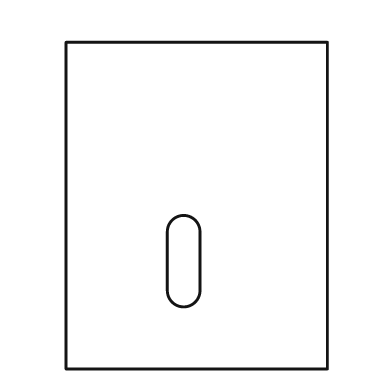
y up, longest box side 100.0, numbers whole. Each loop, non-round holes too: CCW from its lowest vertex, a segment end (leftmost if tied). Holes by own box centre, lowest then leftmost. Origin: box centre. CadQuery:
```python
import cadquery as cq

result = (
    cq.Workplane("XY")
    .moveTo(-40.0, -50.0)
    .lineTo(40.0, -50.0)
    .lineTo(40.0, 50.0)
    .lineTo(-40.0, 50.0)
    .close()
    .moveTo(-9.0, -26.0)
    .threePointArc((-4.0, -31.0), (1.0, -26.0))
    .lineTo(1.0, -8.0)
    .threePointArc((-4.0, -3.0), (-9.0, -8.0))
    .close()
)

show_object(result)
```